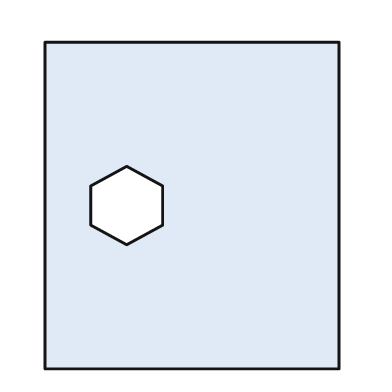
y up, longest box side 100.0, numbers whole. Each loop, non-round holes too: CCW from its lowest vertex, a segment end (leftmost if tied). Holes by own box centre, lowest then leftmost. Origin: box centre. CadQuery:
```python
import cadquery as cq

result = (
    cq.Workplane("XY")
    .moveTo(-45.0, -50.0)
    .lineTo(45.0, -50.0)
    .lineTo(45.0, 50.0)
    .lineTo(-45.0, 50.0)
    .close()
    .moveTo(-20.0, -12.0)
    .lineTo(-9.0, -6.0)
    .lineTo(-9.0, 6.0)
    .lineTo(-20.0, 12.0)
    .lineTo(-31.0, 6.0)
    .lineTo(-31.0, -6.0)
    .close()
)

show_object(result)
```